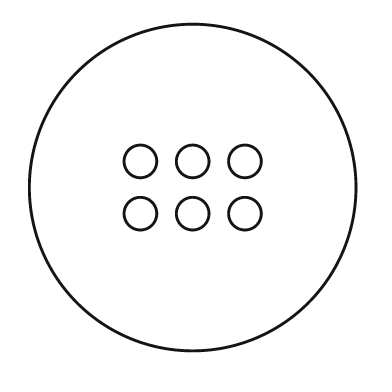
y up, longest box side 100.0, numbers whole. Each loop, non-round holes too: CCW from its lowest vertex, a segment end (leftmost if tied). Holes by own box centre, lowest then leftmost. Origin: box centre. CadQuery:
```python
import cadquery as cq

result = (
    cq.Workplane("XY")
    .moveTo(0.0, 0.0)
    .circle(50.0)
    .moveTo(-16.0, -8.0)
    .circle(5.0)
    .moveTo(0.0, -8.0)
    .circle(5.0)
    .moveTo(16.0, -8.0)
    .circle(5.0)
    .moveTo(-16.0, 8.0)
    .circle(5.0)
    .moveTo(0.0, 8.0)
    .circle(5.0)
    .moveTo(16.0, 8.0)
    .circle(5.0)
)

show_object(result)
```